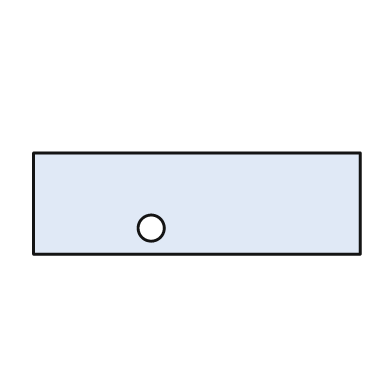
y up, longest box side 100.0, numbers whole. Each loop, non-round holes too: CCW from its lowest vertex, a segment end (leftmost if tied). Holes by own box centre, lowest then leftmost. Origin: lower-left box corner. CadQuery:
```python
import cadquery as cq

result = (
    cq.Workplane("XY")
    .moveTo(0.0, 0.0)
    .lineTo(100.0, 0.0)
    .lineTo(100.0, 31.0)
    .lineTo(0.0, 31.0)
    .close()
    .moveTo(36.0, 8.0)
    .circle(4.0)
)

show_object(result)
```